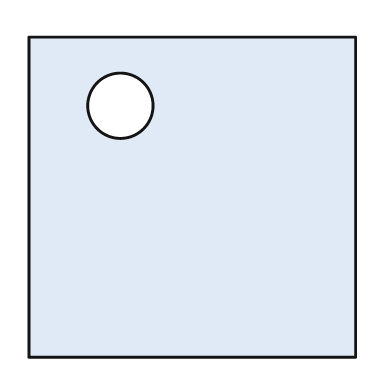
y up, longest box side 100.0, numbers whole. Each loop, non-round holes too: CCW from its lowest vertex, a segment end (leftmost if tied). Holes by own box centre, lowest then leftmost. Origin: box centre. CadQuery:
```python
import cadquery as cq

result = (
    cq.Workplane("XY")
    .moveTo(-50.0, -49.0)
    .lineTo(50.0, -49.0)
    .lineTo(50.0, 49.0)
    .lineTo(-50.0, 49.0)
    .close()
    .moveTo(-22.0, 28.0)
    .circle(10.0)
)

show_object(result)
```